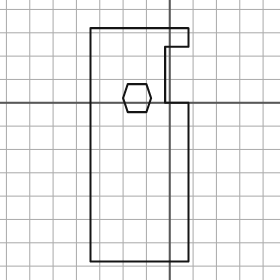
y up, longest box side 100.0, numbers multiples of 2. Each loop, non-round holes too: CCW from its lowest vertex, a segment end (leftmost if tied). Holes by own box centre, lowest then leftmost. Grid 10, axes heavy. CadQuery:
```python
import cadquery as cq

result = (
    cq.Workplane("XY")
    .moveTo(-34.0, -68.0)
    .lineTo(8.0, -68.0)
    .lineTo(8.0, 0.0)
    .lineTo(-2.0, 0.0)
    .lineTo(-2.0, 24.0)
    .lineTo(8.0, 24.0)
    .lineTo(8.0, 32.0)
    .lineTo(-34.0, 32.0)
    .close()
    .moveTo(-18.0, -4.0)
    .lineTo(-10.0, -4.0)
    .lineTo(-8.0, 2.0)
    .lineTo(-10.0, 8.0)
    .lineTo(-18.0, 8.0)
    .lineTo(-20.0, 2.0)
    .close()
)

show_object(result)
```